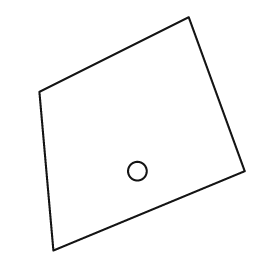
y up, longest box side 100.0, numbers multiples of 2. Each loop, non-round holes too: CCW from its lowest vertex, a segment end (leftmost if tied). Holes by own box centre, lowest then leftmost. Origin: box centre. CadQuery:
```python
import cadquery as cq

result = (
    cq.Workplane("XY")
    .moveTo(-38.0, -50.0)
    .lineTo(44.0, -16.0)
    .lineTo(20.0, 50.0)
    .lineTo(-44.0, 18.0)
    .close()
    .moveTo(-2.0, -16.0)
    .circle(4.0)
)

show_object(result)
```